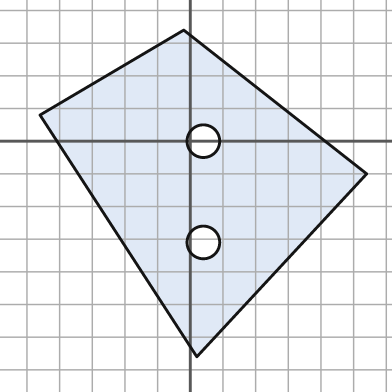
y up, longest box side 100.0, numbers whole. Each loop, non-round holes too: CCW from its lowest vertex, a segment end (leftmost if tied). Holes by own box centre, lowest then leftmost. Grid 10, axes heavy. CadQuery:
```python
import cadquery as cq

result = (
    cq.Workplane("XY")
    .moveTo(2.0, -66.0)
    .lineTo(54.0, -10.0)
    .lineTo(-2.0, 34.0)
    .lineTo(-46.0, 8.0)
    .close()
    .moveTo(4.0, -31.0)
    .circle(5.0)
    .moveTo(4.0, 0.0)
    .circle(5.0)
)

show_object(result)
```